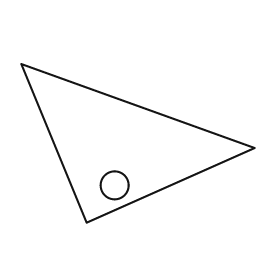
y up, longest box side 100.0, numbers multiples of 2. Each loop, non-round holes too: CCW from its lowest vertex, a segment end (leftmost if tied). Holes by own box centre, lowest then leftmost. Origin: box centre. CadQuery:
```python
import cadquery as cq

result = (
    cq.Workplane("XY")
    .moveTo(-22.0, -34.0)
    .lineTo(50.0, -2.0)
    .lineTo(-50.0, 34.0)
    .close()
    .moveTo(-10.0, -18.0)
    .circle(6.0)
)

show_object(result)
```